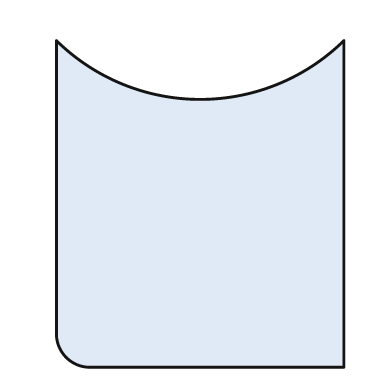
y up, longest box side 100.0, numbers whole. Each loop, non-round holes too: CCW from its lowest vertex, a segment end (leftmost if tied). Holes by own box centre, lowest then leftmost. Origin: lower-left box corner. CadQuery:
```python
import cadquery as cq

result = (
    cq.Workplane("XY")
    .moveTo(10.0, 0.0)
    .lineTo(88.0, 0.0)
    .lineTo(88.0, 100.0)
    .threePointArc((44.0, 82.0), (0.0, 100.0))
    .lineTo(0.0, 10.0)
    .threePointArc((3.0, 3.0), (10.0, 0.0))
    .close()
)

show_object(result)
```